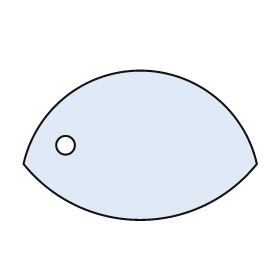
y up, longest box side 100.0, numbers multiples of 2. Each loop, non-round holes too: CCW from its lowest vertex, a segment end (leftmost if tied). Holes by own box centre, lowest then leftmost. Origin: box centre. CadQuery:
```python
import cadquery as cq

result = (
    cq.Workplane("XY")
    .moveTo(-50.0, -8.0)
    .threePointArc((0.0, -32.0), (50.0, -8.0))
    .threePointArc((0.0, 32.0), (-50.0, -8.0))
    .close()
    .moveTo(-32.0, 0.0)
    .circle(4.0)
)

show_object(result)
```